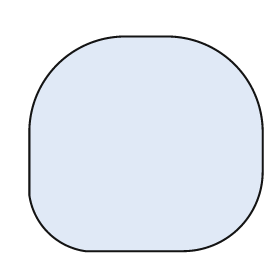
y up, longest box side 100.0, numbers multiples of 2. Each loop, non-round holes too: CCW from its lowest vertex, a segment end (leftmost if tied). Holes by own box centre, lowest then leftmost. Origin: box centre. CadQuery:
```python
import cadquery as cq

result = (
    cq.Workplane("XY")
    .moveTo(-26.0, -46.0)
    .lineTo(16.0, -46.0)
    .threePointArc((40.0, -36.0), (50.0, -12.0))
    .lineTo(50.0, 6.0)
    .threePointArc((38.0, 34.0), (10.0, 46.0))
    .lineTo(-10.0, 46.0)
    .threePointArc((-38.0, 34.0), (-50.0, 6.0))
    .lineTo(-50.0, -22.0)
    .threePointArc((-42.0, -38.0), (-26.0, -46.0))
    .close()
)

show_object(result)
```